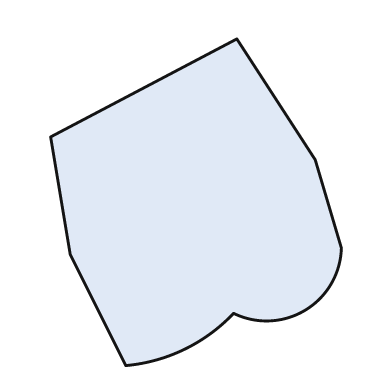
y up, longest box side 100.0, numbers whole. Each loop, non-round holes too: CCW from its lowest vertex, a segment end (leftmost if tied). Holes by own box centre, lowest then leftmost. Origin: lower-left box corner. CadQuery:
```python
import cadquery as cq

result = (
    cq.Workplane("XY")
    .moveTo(23.0, 0.0)
    .threePointArc((41.0, 5.0), (56.0, 16.0))
    .threePointArc((78.0, 17.0), (89.0, 36.0))
    .lineTo(81.0, 63.0)
    .lineTo(57.0, 100.0)
    .lineTo(0.0, 70.0)
    .lineTo(6.0, 34.0)
    .close()
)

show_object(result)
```